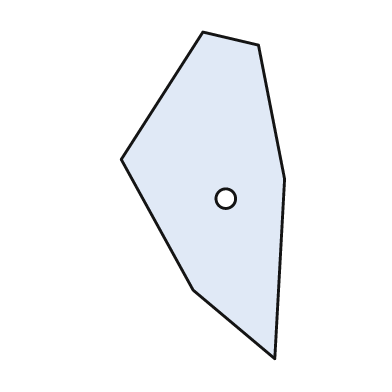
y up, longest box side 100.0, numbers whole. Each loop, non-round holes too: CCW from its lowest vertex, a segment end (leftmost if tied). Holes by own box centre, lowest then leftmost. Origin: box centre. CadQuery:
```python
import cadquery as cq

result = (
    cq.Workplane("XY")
    .moveTo(22.0, -50.0)
    .lineTo(25.0, 5.0)
    .lineTo(17.0, 46.0)
    .lineTo(0.0, 50.0)
    .lineTo(-25.0, 11.0)
    .lineTo(-3.0, -29.0)
    .close()
    .moveTo(7.0, -1.0)
    .circle(3.0)
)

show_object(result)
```